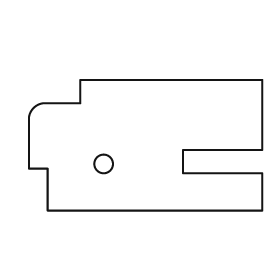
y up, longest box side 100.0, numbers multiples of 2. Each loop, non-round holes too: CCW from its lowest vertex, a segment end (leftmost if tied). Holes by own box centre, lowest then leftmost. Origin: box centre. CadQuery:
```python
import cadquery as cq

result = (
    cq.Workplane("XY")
    .moveTo(-42.0, -28.0)
    .lineTo(50.0, -28.0)
    .lineTo(50.0, -12.0)
    .lineTo(16.0, -12.0)
    .lineTo(16.0, -2.0)
    .lineTo(50.0, -2.0)
    .lineTo(50.0, 28.0)
    .lineTo(-28.0, 28.0)
    .lineTo(-28.0, 18.0)
    .lineTo(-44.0, 18.0)
    .threePointArc((-48.0, 16.0), (-50.0, 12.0))
    .lineTo(-50.0, -10.0)
    .lineTo(-42.0, -10.0)
    .close()
    .moveTo(-18.0, -8.0)
    .circle(4.0)
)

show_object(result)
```